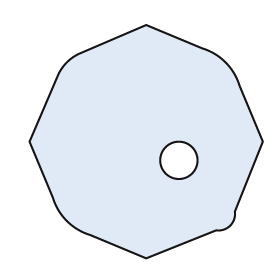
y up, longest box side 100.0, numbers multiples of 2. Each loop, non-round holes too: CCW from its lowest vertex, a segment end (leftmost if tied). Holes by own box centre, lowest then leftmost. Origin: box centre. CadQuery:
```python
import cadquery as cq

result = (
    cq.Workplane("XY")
    .moveTo(0.0, -50.0)
    .lineTo(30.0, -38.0)
    .threePointArc((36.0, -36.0), (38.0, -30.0))
    .lineTo(50.0, 0.0)
    .lineTo(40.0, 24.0)
    .threePointArc((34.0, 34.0), (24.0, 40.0))
    .lineTo(0.0, 50.0)
    .lineTo(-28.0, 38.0)
    .threePointArc((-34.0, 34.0), (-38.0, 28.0))
    .lineTo(-50.0, 0.0)
    .lineTo(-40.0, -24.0)
    .threePointArc((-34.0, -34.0), (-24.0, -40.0))
    .close()
    .moveTo(14.0, -8.0)
    .circle(8.0)
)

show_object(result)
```